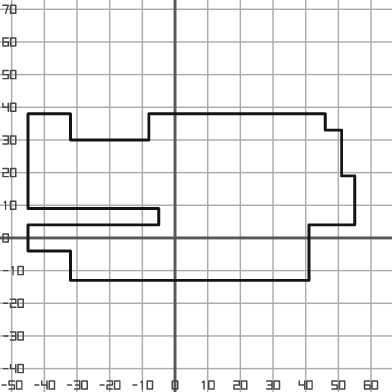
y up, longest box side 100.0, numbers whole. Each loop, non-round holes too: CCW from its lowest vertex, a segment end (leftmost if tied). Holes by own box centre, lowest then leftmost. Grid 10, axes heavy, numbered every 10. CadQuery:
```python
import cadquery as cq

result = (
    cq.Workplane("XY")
    .moveTo(-32.0, -13.0)
    .lineTo(41.0, -13.0)
    .lineTo(41.0, 4.0)
    .lineTo(55.0, 4.0)
    .lineTo(55.0, 19.0)
    .lineTo(51.0, 19.0)
    .lineTo(51.0, 33.0)
    .lineTo(46.0, 33.0)
    .lineTo(46.0, 38.0)
    .lineTo(-8.0, 38.0)
    .lineTo(-8.0, 30.0)
    .lineTo(-32.0, 30.0)
    .lineTo(-32.0, 38.0)
    .lineTo(-45.0, 38.0)
    .lineTo(-45.0, 9.0)
    .lineTo(-5.0, 9.0)
    .lineTo(-5.0, 4.0)
    .lineTo(-45.0, 4.0)
    .lineTo(-45.0, -4.0)
    .lineTo(-32.0, -4.0)
    .close()
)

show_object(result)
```